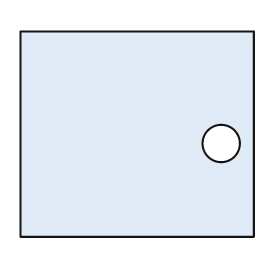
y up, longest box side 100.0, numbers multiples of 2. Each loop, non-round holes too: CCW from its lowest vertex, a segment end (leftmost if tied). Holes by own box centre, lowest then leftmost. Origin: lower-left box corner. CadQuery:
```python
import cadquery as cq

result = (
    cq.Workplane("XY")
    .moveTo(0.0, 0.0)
    .lineTo(100.0, 0.0)
    .lineTo(100.0, 88.0)
    .lineTo(0.0, 88.0)
    .close()
    .moveTo(86.0, 40.0)
    .circle(8.0)
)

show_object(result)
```